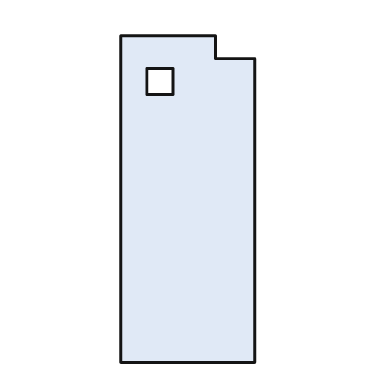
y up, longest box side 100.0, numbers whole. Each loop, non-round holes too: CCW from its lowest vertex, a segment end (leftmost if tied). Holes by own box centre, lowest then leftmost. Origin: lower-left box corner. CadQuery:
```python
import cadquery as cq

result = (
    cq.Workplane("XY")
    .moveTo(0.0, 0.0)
    .lineTo(41.0, 0.0)
    .lineTo(41.0, 93.0)
    .lineTo(29.0, 93.0)
    .lineTo(29.0, 100.0)
    .lineTo(0.0, 100.0)
    .close()
    .moveTo(8.0, 82.0)
    .lineTo(16.0, 82.0)
    .lineTo(16.0, 90.0)
    .lineTo(8.0, 90.0)
    .close()
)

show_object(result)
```